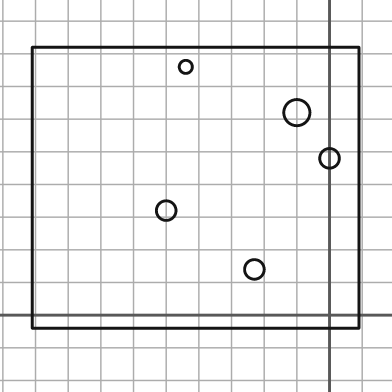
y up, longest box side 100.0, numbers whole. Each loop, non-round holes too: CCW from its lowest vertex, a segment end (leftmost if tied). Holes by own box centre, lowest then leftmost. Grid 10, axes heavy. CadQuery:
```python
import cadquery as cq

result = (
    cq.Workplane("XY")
    .moveTo(-91.0, -4.0)
    .lineTo(9.0, -4.0)
    .lineTo(9.0, 82.0)
    .lineTo(-91.0, 82.0)
    .close()
    .moveTo(-23.0, 14.0)
    .circle(3.0)
    .moveTo(-50.0, 32.0)
    .circle(3.0)
    .moveTo(0.0, 48.0)
    .circle(3.0)
    .moveTo(-10.0, 62.0)
    .circle(4.0)
    .moveTo(-44.0, 76.0)
    .circle(2.0)
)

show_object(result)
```